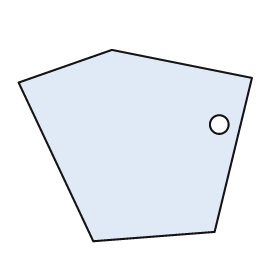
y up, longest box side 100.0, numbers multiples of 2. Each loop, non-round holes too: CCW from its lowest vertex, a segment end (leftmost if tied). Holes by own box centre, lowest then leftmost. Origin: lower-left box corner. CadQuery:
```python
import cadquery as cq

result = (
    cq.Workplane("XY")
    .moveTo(32.0, 0.0)
    .lineTo(84.0, 4.0)
    .lineTo(100.0, 70.0)
    .lineTo(40.0, 82.0)
    .lineTo(0.0, 68.0)
    .close()
    .moveTo(86.0, 50.0)
    .circle(4.0)
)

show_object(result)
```